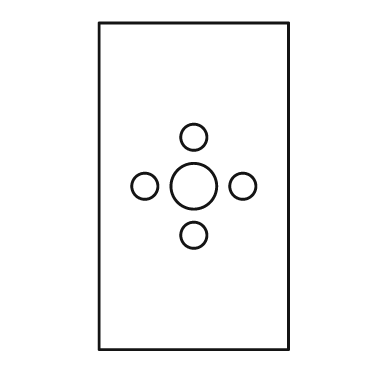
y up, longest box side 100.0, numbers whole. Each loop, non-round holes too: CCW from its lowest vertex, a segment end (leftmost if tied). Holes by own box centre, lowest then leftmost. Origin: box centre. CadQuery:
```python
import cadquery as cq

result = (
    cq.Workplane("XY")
    .moveTo(-29.0, -50.0)
    .lineTo(29.0, -50.0)
    .lineTo(29.0, 50.0)
    .lineTo(-29.0, 50.0)
    .close()
    .moveTo(0.0, -15.0)
    .circle(4.0)
    .moveTo(-15.0, 0.0)
    .circle(4.0)
    .moveTo(0.0, 0.0)
    .circle(7.0)
    .moveTo(15.0, 0.0)
    .circle(4.0)
    .moveTo(0.0, 15.0)
    .circle(4.0)
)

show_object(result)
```